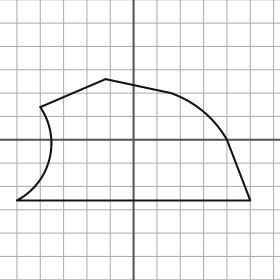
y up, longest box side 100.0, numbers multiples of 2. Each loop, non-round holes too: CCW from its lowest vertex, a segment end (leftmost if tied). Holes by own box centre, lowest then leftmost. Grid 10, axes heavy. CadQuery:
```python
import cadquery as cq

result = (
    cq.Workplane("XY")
    .moveTo(-50.0, -26.0)
    .lineTo(50.0, -26.0)
    .lineTo(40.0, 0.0)
    .threePointArc((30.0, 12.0), (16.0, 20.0))
    .lineTo(-12.0, 26.0)
    .lineTo(-40.0, 14.0)
    .threePointArc((-36.0, -8.0), (-50.0, -26.0))
    .close()
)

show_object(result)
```